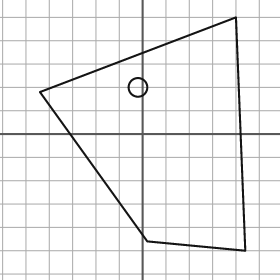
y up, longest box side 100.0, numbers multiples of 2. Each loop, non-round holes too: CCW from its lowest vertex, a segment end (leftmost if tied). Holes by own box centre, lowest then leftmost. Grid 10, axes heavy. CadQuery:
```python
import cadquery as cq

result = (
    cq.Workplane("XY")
    .moveTo(44.0, -50.0)
    .lineTo(40.0, 50.0)
    .lineTo(-44.0, 18.0)
    .lineTo(2.0, -46.0)
    .close()
    .moveTo(-2.0, 20.0)
    .circle(4.0)
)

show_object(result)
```